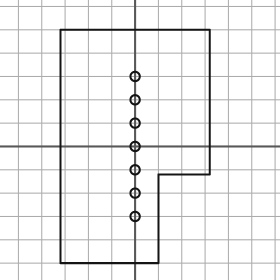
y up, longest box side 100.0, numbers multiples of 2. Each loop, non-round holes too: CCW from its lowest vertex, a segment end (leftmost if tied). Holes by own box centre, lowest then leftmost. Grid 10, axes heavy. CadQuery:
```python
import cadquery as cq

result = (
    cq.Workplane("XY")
    .moveTo(-32.0, -50.0)
    .lineTo(10.0, -50.0)
    .lineTo(10.0, -12.0)
    .lineTo(32.0, -12.0)
    .lineTo(32.0, 50.0)
    .lineTo(-32.0, 50.0)
    .close()
    .moveTo(0.0, -30.0)
    .circle(2.0)
    .moveTo(0.0, -20.0)
    .circle(2.0)
    .moveTo(0.0, -10.0)
    .circle(2.0)
    .moveTo(0.0, 0.0)
    .circle(2.0)
    .moveTo(0.0, 10.0)
    .circle(2.0)
    .moveTo(0.0, 20.0)
    .circle(2.0)
    .moveTo(0.0, 30.0)
    .circle(2.0)
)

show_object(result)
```